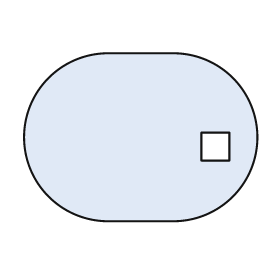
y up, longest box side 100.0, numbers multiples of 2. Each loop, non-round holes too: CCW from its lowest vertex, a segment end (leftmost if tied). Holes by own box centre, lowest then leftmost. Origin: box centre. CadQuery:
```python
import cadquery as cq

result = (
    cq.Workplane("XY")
    .moveTo(-14.0, -36.0)
    .lineTo(14.0, -36.0)
    .threePointArc((50.0, 0.0), (14.0, 36.0))
    .lineTo(-14.0, 36.0)
    .threePointArc((-50.0, 0.0), (-14.0, -36.0))
    .close()
    .moveTo(26.0, -10.0)
    .lineTo(38.0, -10.0)
    .lineTo(38.0, 2.0)
    .lineTo(26.0, 2.0)
    .close()
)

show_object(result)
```